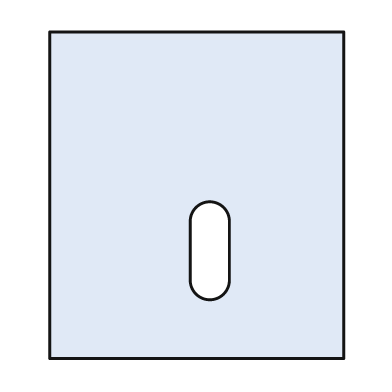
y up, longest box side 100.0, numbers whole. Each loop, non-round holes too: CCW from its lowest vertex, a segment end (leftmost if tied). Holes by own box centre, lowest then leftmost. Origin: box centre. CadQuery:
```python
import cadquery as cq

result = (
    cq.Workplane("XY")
    .moveTo(-45.0, -50.0)
    .lineTo(45.0, -50.0)
    .lineTo(45.0, 50.0)
    .lineTo(-45.0, 50.0)
    .close()
    .moveTo(-2.0, -26.0)
    .threePointArc((4.0, -32.0), (10.0, -26.0))
    .lineTo(10.0, -8.0)
    .threePointArc((4.0, -2.0), (-2.0, -8.0))
    .close()
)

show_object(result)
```